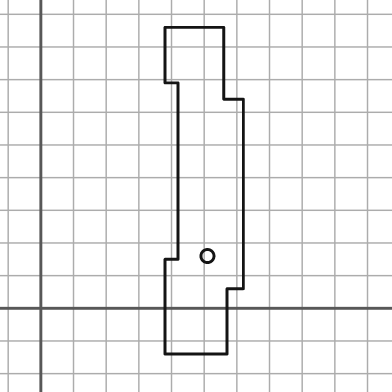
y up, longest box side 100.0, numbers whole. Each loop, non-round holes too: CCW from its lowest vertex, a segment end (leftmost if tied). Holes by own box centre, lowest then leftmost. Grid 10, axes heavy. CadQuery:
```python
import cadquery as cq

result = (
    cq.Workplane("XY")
    .moveTo(38.0, -14.0)
    .lineTo(57.0, -14.0)
    .lineTo(57.0, 6.0)
    .lineTo(62.0, 6.0)
    .lineTo(62.0, 64.0)
    .lineTo(56.0, 64.0)
    .lineTo(56.0, 86.0)
    .lineTo(38.0, 86.0)
    .lineTo(38.0, 69.0)
    .lineTo(42.0, 69.0)
    .lineTo(42.0, 15.0)
    .lineTo(38.0, 15.0)
    .close()
    .moveTo(51.0, 16.0)
    .circle(2.0)
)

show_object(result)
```